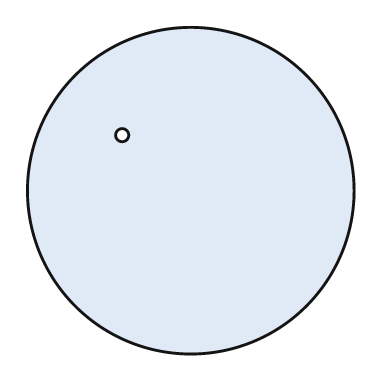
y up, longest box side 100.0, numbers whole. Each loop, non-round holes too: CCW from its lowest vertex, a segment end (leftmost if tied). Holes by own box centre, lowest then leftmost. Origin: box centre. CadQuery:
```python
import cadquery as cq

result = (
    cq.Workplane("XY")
    .moveTo(0.0, 0.0)
    .circle(50.0)
    .moveTo(-21.0, 17.0)
    .circle(2.0)
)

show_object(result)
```